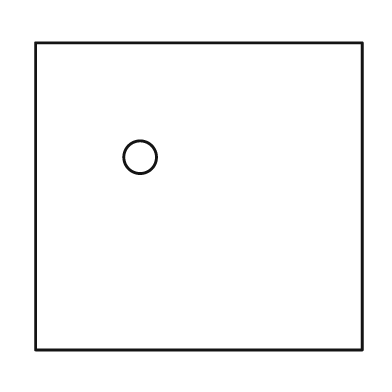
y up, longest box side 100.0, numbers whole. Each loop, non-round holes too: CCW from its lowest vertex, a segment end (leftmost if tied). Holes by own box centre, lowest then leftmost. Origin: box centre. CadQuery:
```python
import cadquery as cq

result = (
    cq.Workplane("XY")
    .moveTo(-50.0, -47.0)
    .lineTo(50.0, -47.0)
    .lineTo(50.0, 47.0)
    .lineTo(-50.0, 47.0)
    .close()
    .moveTo(-18.0, 12.0)
    .circle(5.0)
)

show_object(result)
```